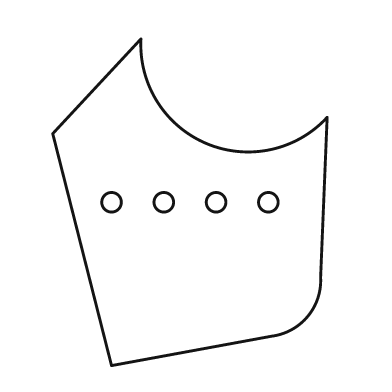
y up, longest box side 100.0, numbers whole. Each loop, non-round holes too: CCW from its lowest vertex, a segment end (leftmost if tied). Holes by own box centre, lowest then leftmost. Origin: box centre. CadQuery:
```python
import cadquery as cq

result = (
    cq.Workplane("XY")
    .moveTo(-24.0, -50.0)
    .lineTo(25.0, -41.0)
    .threePointArc((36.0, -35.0), (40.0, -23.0))
    .lineTo(42.0, 26.0)
    .threePointArc((5.0, 18.0), (-15.0, 50.0))
    .lineTo(-42.0, 21.0)
    .close()
    .moveTo(-24.0, 0.0)
    .circle(3.0)
    .moveTo(-8.0, 0.0)
    .circle(3.0)
    .moveTo(8.0, 0.0)
    .circle(3.0)
    .moveTo(24.0, 0.0)
    .circle(3.0)
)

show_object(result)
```